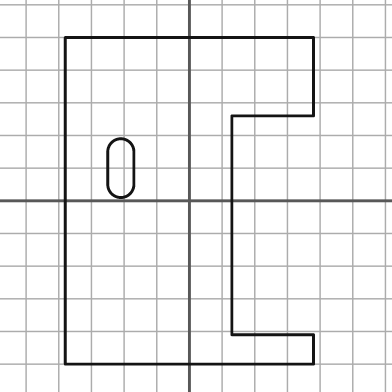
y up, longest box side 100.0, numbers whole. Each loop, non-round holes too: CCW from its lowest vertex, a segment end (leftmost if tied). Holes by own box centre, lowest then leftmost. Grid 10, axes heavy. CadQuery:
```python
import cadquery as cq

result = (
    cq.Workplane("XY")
    .moveTo(-38.0, -50.0)
    .lineTo(38.0, -50.0)
    .lineTo(38.0, -41.0)
    .lineTo(13.0, -41.0)
    .lineTo(13.0, 26.0)
    .lineTo(38.0, 26.0)
    .lineTo(38.0, 50.0)
    .lineTo(-38.0, 50.0)
    .close()
    .moveTo(-25.0, 5.0)
    .threePointArc((-21.0, 1.0), (-17.0, 5.0))
    .lineTo(-17.0, 15.0)
    .threePointArc((-21.0, 19.0), (-25.0, 15.0))
    .close()
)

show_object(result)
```